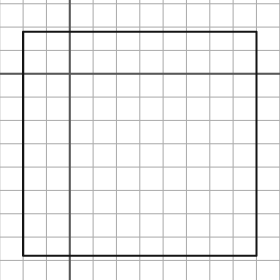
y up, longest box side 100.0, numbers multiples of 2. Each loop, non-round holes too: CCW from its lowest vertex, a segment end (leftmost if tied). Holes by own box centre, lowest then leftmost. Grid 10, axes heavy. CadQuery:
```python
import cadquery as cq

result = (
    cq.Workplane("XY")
    .moveTo(-20.0, -78.0)
    .lineTo(80.0, -78.0)
    .lineTo(80.0, 18.0)
    .lineTo(-20.0, 18.0)
    .close()
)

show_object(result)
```